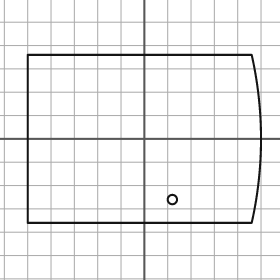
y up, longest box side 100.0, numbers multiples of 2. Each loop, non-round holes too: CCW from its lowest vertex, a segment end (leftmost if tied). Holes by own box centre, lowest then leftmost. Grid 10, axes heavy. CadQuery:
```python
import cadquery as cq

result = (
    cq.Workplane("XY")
    .moveTo(-50.0, -36.0)
    .lineTo(46.0, -36.0)
    .threePointArc((50.0, 0.0), (46.0, 36.0))
    .lineTo(-50.0, 36.0)
    .close()
    .moveTo(12.0, -26.0)
    .circle(2.0)
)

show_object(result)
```